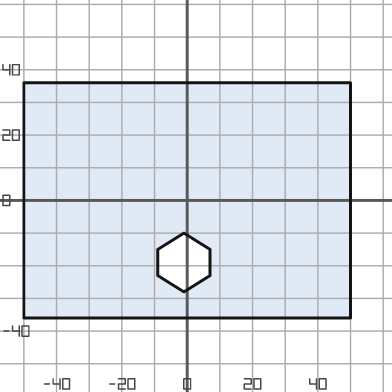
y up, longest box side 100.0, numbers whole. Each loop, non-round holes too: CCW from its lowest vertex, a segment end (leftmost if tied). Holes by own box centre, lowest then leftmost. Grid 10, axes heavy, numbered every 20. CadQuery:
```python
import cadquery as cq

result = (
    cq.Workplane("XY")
    .moveTo(-50.0, -36.0)
    .lineTo(50.0, -36.0)
    .lineTo(50.0, 36.0)
    .lineTo(-50.0, 36.0)
    .close()
    .moveTo(-1.0, -28.0)
    .lineTo(7.0, -23.0)
    .lineTo(7.0, -15.0)
    .lineTo(-1.0, -10.0)
    .lineTo(-9.0, -15.0)
    .lineTo(-9.0, -23.0)
    .close()
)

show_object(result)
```